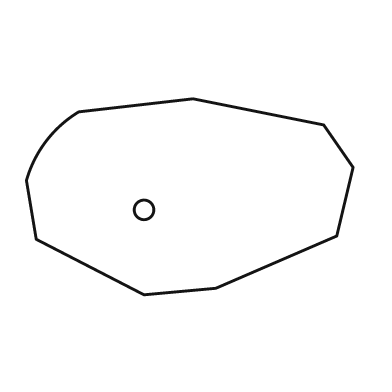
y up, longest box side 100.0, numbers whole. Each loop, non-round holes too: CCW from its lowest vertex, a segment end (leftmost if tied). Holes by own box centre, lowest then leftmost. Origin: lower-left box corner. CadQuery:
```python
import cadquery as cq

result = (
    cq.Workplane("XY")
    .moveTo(36.0, 0.0)
    .lineTo(58.0, 2.0)
    .lineTo(95.0, 18.0)
    .lineTo(100.0, 39.0)
    .lineTo(91.0, 52.0)
    .lineTo(51.0, 60.0)
    .lineTo(16.0, 56.0)
    .threePointArc((6.0, 47.0), (0.0, 35.0))
    .lineTo(3.0, 17.0)
    .close()
    .moveTo(36.0, 26.0)
    .circle(3.0)
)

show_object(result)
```